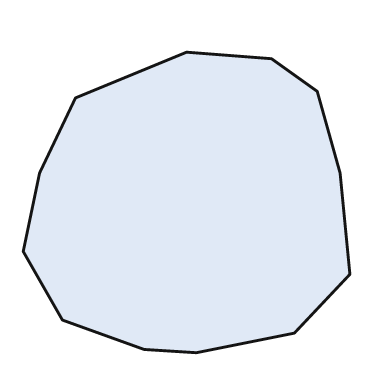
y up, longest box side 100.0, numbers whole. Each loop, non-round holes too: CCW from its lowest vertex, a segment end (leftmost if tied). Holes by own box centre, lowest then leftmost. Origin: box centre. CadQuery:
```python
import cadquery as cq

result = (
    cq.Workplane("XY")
    .moveTo(3.0, -46.0)
    .lineTo(33.0, -40.0)
    .lineTo(50.0, -22.0)
    .lineTo(47.0, 9.0)
    .lineTo(40.0, 34.0)
    .lineTo(26.0, 44.0)
    .lineTo(0.0, 46.0)
    .lineTo(-34.0, 32.0)
    .lineTo(-45.0, 9.0)
    .lineTo(-50.0, -15.0)
    .lineTo(-38.0, -36.0)
    .lineTo(-13.0, -45.0)
    .close()
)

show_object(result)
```